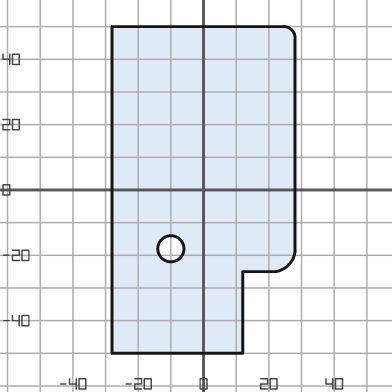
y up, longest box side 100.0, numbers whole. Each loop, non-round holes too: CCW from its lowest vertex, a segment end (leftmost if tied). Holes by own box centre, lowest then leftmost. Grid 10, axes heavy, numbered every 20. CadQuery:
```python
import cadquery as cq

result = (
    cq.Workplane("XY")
    .moveTo(-28.0, -50.0)
    .lineTo(12.0, -50.0)
    .lineTo(12.0, -25.0)
    .lineTo(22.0, -25.0)
    .threePointArc((26.0, -23.0), (28.0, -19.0))
    .lineTo(28.0, 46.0)
    .threePointArc((27.0, 49.0), (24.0, 50.0))
    .lineTo(-28.0, 50.0)
    .close()
    .moveTo(-10.0, -18.0)
    .circle(4.0)
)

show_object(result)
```